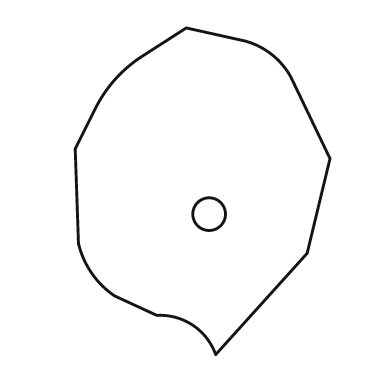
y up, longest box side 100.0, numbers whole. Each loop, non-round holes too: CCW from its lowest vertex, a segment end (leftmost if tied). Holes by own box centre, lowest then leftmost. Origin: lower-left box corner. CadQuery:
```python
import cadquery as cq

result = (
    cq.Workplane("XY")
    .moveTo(43.0, 0.0)
    .lineTo(71.0, 31.0)
    .lineTo(78.0, 60.0)
    .lineTo(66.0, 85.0)
    .threePointArc((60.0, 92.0), (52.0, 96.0))
    .lineTo(34.0, 100.0)
    .lineTo(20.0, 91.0)
    .threePointArc((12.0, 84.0), (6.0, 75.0))
    .lineTo(0.0, 63.0)
    .lineTo(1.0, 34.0)
    .threePointArc((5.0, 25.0), (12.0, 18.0))
    .lineTo(25.0, 12.0)
    .threePointArc((36.0, 9.0), (43.0, 0.0))
    .close()
    .moveTo(41.0, 43.0)
    .circle(5.0)
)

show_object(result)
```